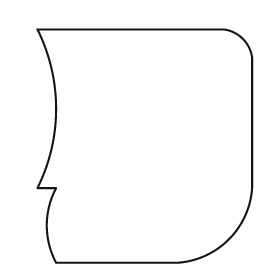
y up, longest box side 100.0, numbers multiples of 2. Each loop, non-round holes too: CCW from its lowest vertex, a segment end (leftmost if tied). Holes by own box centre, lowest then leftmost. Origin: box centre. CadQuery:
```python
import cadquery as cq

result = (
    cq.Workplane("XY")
    .moveTo(-38.0, -50.0)
    .lineTo(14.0, -50.0)
    .threePointArc((36.0, -40.0), (46.0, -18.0))
    .lineTo(46.0, 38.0)
    .threePointArc((42.0, 46.0), (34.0, 50.0))
    .lineTo(-46.0, 50.0)
    .threePointArc((-38.0, 16.0), (-46.0, -18.0))
    .lineTo(-38.0, -18.0)
    .threePointArc((-42.0, -34.0), (-38.0, -50.0))
    .close()
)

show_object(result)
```